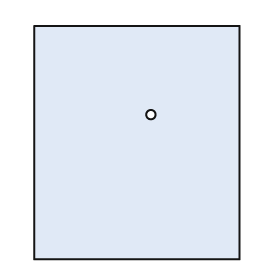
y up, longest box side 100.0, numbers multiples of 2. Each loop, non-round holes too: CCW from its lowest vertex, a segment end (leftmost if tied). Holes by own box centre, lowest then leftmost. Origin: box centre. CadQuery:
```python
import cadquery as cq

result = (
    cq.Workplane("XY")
    .moveTo(-44.0, -50.0)
    .lineTo(44.0, -50.0)
    .lineTo(44.0, 50.0)
    .lineTo(-44.0, 50.0)
    .close()
    .moveTo(6.0, 12.0)
    .circle(2.0)
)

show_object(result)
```